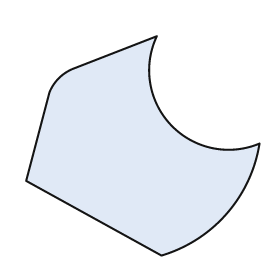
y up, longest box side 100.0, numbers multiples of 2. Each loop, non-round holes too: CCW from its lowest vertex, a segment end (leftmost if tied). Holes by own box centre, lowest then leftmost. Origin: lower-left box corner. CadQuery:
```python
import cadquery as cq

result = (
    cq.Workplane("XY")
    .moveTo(58.0, 0.0)
    .threePointArc((86.0, 18.0), (100.0, 48.0))
    .threePointArc((62.0, 56.0), (56.0, 94.0))
    .lineTo(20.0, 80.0)
    .threePointArc((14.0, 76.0), (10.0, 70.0))
    .lineTo(0.0, 32.0)
    .close()
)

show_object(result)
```